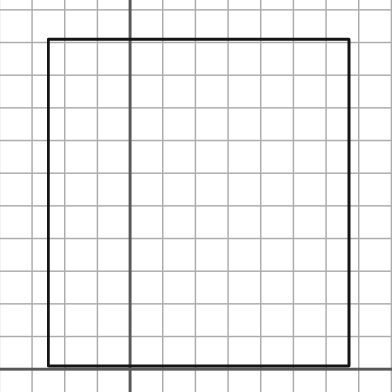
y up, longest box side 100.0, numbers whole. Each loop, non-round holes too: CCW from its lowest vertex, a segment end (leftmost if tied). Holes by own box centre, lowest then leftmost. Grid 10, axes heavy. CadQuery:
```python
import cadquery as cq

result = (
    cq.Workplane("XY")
    .moveTo(-25.0, 1.0)
    .lineTo(67.0, 1.0)
    .lineTo(67.0, 101.0)
    .lineTo(-25.0, 101.0)
    .close()
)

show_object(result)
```